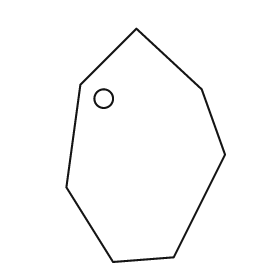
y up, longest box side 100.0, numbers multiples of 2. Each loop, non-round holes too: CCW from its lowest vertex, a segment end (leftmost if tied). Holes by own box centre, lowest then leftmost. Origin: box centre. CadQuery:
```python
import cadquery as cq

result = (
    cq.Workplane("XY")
    .moveTo(-14.0, -50.0)
    .lineTo(12.0, -48.0)
    .lineTo(34.0, -4.0)
    .lineTo(24.0, 24.0)
    .lineTo(-4.0, 50.0)
    .lineTo(-28.0, 26.0)
    .lineTo(-34.0, -18.0)
    .close()
    .moveTo(-18.0, 20.0)
    .circle(4.0)
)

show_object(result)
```